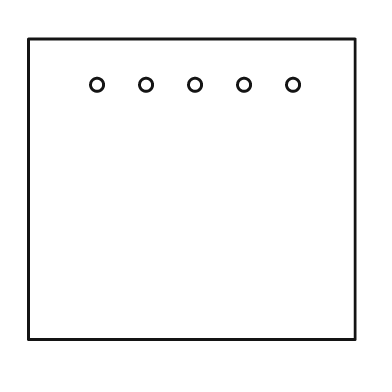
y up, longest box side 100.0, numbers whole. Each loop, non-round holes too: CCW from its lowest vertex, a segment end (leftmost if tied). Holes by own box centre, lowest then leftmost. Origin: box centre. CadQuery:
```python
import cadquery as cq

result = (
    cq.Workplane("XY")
    .moveTo(-50.0, -46.0)
    .lineTo(50.0, -46.0)
    .lineTo(50.0, 46.0)
    .lineTo(-50.0, 46.0)
    .close()
    .moveTo(-29.0, 32.0)
    .circle(2.0)
    .moveTo(-14.0, 32.0)
    .circle(2.0)
    .moveTo(1.0, 32.0)
    .circle(2.0)
    .moveTo(16.0, 32.0)
    .circle(2.0)
    .moveTo(31.0, 32.0)
    .circle(2.0)
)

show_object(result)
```